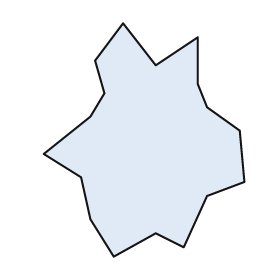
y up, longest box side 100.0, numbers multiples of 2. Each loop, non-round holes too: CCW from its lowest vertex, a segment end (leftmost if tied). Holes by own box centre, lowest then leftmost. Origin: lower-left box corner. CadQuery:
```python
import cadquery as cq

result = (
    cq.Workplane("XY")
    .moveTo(30.0, 0.0)
    .lineTo(48.0, 10.0)
    .lineTo(60.0, 4.0)
    .lineTo(70.0, 26.0)
    .lineTo(86.0, 32.0)
    .lineTo(84.0, 54.0)
    .lineTo(70.0, 64.0)
    .lineTo(66.0, 74.0)
    .lineTo(66.0, 94.0)
    .lineTo(48.0, 82.0)
    .lineTo(34.0, 100.0)
    .lineTo(22.0, 84.0)
    .lineTo(26.0, 70.0)
    .lineTo(20.0, 60.0)
    .lineTo(0.0, 44.0)
    .lineTo(16.0, 34.0)
    .lineTo(20.0, 16.0)
    .close()
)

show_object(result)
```